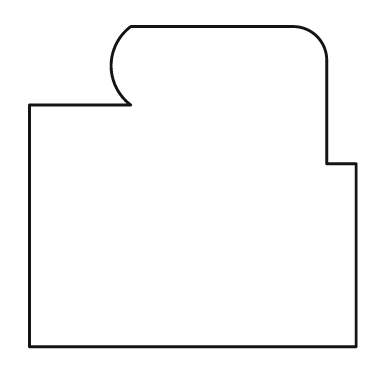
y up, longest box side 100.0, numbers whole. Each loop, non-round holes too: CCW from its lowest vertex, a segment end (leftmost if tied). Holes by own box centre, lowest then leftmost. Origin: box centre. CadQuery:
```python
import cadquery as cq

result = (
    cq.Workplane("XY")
    .moveTo(-50.0, -49.0)
    .lineTo(50.0, -49.0)
    .lineTo(50.0, 7.0)
    .lineTo(41.0, 7.0)
    .lineTo(41.0, 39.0)
    .threePointArc((38.0, 46.0), (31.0, 49.0))
    .lineTo(-19.0, 49.0)
    .threePointArc((-25.0, 37.0), (-19.0, 25.0))
    .lineTo(-50.0, 25.0)
    .close()
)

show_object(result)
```